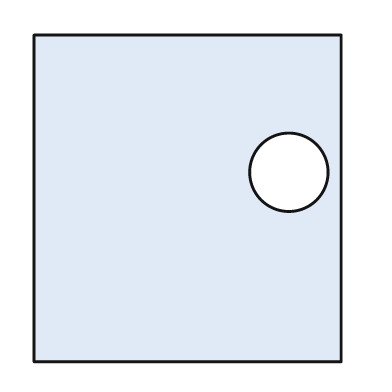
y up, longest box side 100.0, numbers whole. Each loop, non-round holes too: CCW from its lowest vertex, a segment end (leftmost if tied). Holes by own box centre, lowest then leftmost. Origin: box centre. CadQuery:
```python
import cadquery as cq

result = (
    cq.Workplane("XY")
    .moveTo(-47.0, -50.0)
    .lineTo(47.0, -50.0)
    .lineTo(47.0, 50.0)
    .lineTo(-47.0, 50.0)
    .close()
    .moveTo(31.0, 8.0)
    .circle(12.0)
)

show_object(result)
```